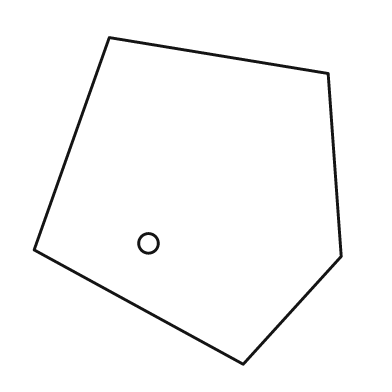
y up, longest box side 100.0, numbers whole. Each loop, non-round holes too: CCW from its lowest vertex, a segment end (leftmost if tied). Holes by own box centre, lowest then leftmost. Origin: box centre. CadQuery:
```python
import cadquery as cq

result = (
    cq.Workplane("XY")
    .moveTo(17.0, -50.0)
    .lineTo(47.0, -17.0)
    .lineTo(43.0, 39.0)
    .lineTo(-24.0, 50.0)
    .lineTo(-47.0, -15.0)
    .close()
    .moveTo(-12.0, -13.0)
    .circle(3.0)
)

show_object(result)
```